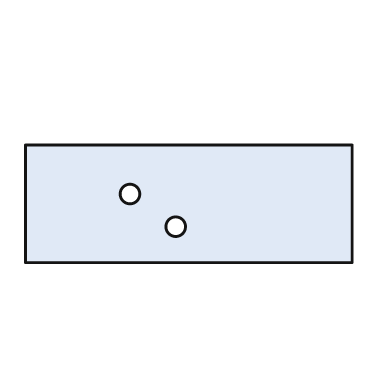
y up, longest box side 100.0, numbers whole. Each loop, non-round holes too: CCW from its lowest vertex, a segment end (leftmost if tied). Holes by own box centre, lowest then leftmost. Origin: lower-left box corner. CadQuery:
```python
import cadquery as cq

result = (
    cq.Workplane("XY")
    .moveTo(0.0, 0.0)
    .lineTo(100.0, 0.0)
    .lineTo(100.0, 36.0)
    .lineTo(0.0, 36.0)
    .close()
    .moveTo(46.0, 11.0)
    .circle(3.0)
    .moveTo(32.0, 21.0)
    .circle(3.0)
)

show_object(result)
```